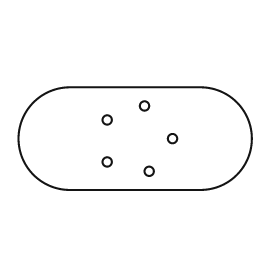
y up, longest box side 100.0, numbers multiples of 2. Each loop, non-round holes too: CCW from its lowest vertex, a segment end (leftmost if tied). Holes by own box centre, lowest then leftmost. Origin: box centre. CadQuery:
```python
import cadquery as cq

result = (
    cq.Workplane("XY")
    .moveTo(-28.0, -22.0)
    .lineTo(28.0, -22.0)
    .threePointArc((50.0, 0.0), (28.0, 22.0))
    .lineTo(-28.0, 22.0)
    .threePointArc((-50.0, 0.0), (-28.0, -22.0))
    .close()
    .moveTo(6.0, -14.0)
    .circle(2.0)
    .moveTo(-12.0, -10.0)
    .circle(2.0)
    .moveTo(16.0, 0.0)
    .circle(2.0)
    .moveTo(-12.0, 8.0)
    .circle(2.0)
    .moveTo(4.0, 14.0)
    .circle(2.0)
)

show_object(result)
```